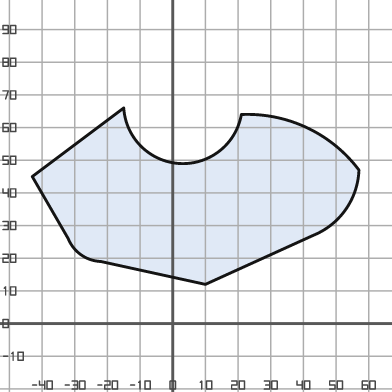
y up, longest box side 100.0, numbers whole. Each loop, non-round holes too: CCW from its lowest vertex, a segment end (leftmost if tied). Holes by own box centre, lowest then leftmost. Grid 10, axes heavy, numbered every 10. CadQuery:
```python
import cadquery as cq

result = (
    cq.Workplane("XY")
    .moveTo(10.0, 12.0)
    .lineTo(43.0, 27.0)
    .threePointArc((53.0, 35.0), (57.0, 47.0))
    .threePointArc((41.0, 60.0), (21.0, 64.0))
    .threePointArc((2.0, 49.0), (-15.0, 66.0))
    .lineTo(-43.0, 45.0)
    .lineTo(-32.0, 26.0)
    .threePointArc((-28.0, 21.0), (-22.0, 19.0))
    .close()
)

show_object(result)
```